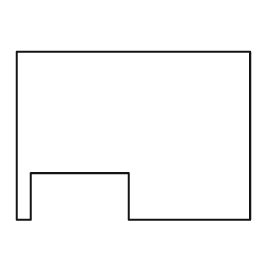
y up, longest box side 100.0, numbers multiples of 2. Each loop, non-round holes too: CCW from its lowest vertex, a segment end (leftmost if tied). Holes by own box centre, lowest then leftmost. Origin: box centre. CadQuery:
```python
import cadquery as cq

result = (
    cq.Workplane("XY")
    .moveTo(-50.0, -36.0)
    .lineTo(-44.0, -36.0)
    .lineTo(-44.0, -16.0)
    .lineTo(-2.0, -16.0)
    .lineTo(-2.0, -36.0)
    .lineTo(50.0, -36.0)
    .lineTo(50.0, 36.0)
    .lineTo(-50.0, 36.0)
    .close()
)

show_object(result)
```